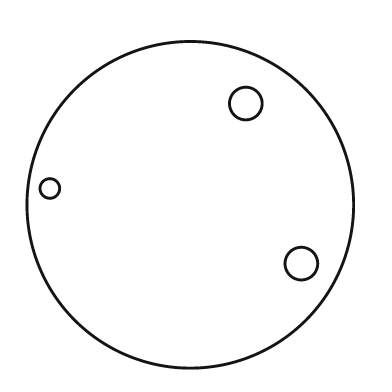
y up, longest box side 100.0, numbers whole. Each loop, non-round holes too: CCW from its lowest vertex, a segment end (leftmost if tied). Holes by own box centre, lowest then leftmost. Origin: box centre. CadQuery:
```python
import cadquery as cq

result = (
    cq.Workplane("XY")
    .moveTo(0.0, 0.0)
    .circle(50.0)
    .moveTo(34.0, -18.0)
    .circle(5.0)
    .moveTo(-43.0, 5.0)
    .circle(3.0)
    .moveTo(17.0, 31.0)
    .circle(5.0)
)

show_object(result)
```